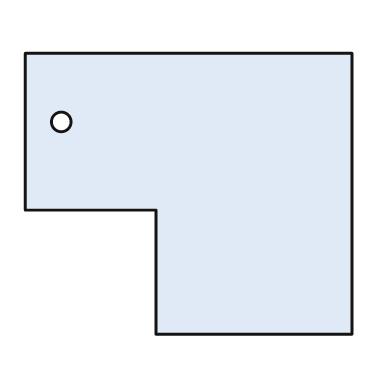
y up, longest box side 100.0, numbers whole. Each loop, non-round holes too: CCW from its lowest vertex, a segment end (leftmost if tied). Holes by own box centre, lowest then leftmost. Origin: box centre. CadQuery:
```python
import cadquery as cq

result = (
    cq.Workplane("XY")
    .moveTo(-10.0, -43.0)
    .lineTo(50.0, -43.0)
    .lineTo(50.0, 43.0)
    .lineTo(-50.0, 43.0)
    .lineTo(-50.0, -5.0)
    .lineTo(-10.0, -5.0)
    .close()
    .moveTo(-39.0, 22.0)
    .circle(3.0)
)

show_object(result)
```